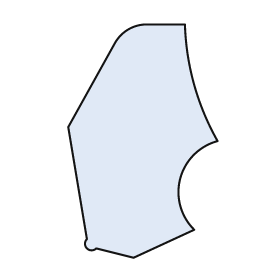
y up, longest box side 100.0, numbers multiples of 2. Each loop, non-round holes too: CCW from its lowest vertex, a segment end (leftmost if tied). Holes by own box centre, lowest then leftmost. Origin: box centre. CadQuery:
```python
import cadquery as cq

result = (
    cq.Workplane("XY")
    .moveTo(-4.0, -50.0)
    .lineTo(22.0, -38.0)
    .threePointArc((16.0, -16.0), (32.0, 0.0))
    .threePointArc((22.0, 24.0), (18.0, 50.0))
    .lineTo(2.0, 50.0)
    .threePointArc((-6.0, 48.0), (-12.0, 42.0))
    .lineTo(-32.0, 6.0)
    .lineTo(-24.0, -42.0)
    .threePointArc((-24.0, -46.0), (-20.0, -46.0))
    .close()
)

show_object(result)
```